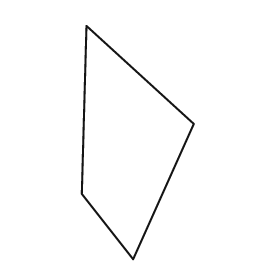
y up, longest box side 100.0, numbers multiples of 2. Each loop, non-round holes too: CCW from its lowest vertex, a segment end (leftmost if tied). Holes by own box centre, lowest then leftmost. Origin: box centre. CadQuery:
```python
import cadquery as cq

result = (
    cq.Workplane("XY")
    .moveTo(-2.0, -50.0)
    .lineTo(24.0, 8.0)
    .lineTo(-22.0, 50.0)
    .lineTo(-24.0, -22.0)
    .close()
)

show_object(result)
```